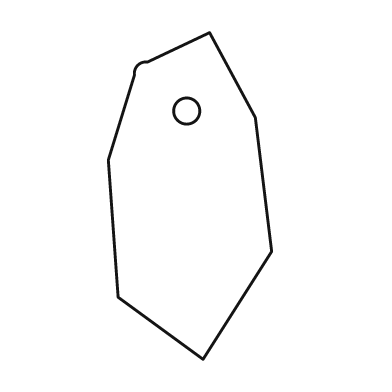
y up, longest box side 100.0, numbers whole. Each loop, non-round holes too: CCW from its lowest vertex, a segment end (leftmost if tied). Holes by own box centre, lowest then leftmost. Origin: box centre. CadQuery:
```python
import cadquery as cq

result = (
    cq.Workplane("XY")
    .moveTo(4.0, -50.0)
    .lineTo(25.0, -17.0)
    .lineTo(20.0, 24.0)
    .lineTo(6.0, 50.0)
    .lineTo(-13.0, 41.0)
    .threePointArc((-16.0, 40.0), (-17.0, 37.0))
    .lineTo(-25.0, 11.0)
    .lineTo(-22.0, -31.0)
    .close()
    .moveTo(-1.0, 26.0)
    .circle(4.0)
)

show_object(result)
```